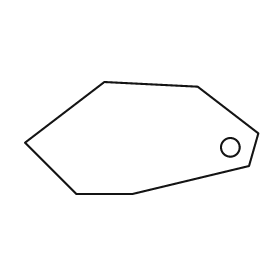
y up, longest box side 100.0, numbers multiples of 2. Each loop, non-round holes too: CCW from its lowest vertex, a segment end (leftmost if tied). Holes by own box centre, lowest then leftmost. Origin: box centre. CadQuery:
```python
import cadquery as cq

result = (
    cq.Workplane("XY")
    .moveTo(-28.0, -24.0)
    .lineTo(-4.0, -24.0)
    .lineTo(46.0, -12.0)
    .lineTo(50.0, 2.0)
    .lineTo(24.0, 22.0)
    .lineTo(-16.0, 24.0)
    .lineTo(-50.0, -2.0)
    .close()
    .moveTo(38.0, -4.0)
    .circle(4.0)
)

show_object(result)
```